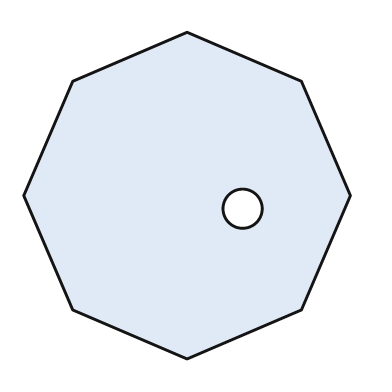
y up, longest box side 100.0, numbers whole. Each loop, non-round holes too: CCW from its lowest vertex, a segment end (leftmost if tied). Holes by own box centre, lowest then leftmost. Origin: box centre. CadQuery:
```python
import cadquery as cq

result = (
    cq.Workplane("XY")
    .moveTo(0.0, -50.0)
    .lineTo(35.0, -35.0)
    .lineTo(50.0, 0.0)
    .lineTo(35.0, 35.0)
    .lineTo(0.0, 50.0)
    .lineTo(-35.0, 35.0)
    .lineTo(-50.0, 0.0)
    .lineTo(-35.0, -35.0)
    .close()
    .moveTo(17.0, -4.0)
    .circle(6.0)
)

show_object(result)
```